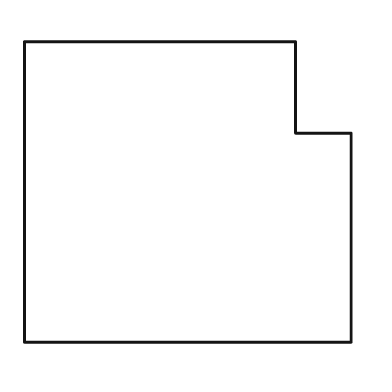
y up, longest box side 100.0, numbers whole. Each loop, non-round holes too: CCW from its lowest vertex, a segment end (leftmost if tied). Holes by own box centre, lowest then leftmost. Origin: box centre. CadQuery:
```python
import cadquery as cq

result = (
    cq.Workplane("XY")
    .moveTo(-50.0, -46.0)
    .lineTo(50.0, -46.0)
    .lineTo(50.0, 18.0)
    .lineTo(33.0, 18.0)
    .lineTo(33.0, 46.0)
    .lineTo(-50.0, 46.0)
    .close()
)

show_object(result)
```